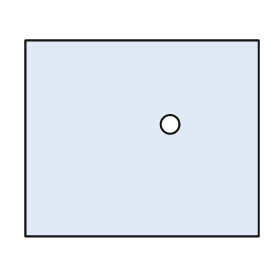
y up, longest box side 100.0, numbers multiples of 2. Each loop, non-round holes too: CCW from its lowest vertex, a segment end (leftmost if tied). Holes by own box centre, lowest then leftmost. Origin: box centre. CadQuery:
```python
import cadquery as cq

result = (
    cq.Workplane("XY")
    .moveTo(-50.0, -42.0)
    .lineTo(50.0, -42.0)
    .lineTo(50.0, 42.0)
    .lineTo(-50.0, 42.0)
    .close()
    .moveTo(12.0, 6.0)
    .circle(4.0)
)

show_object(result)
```